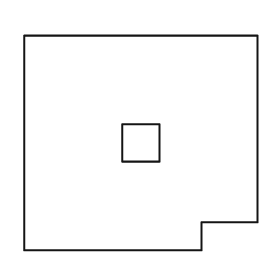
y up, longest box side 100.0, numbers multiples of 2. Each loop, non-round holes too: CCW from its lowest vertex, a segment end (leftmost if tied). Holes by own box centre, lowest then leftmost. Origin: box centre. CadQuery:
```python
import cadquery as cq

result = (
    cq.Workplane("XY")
    .moveTo(-50.0, -46.0)
    .lineTo(26.0, -46.0)
    .lineTo(26.0, -34.0)
    .lineTo(50.0, -34.0)
    .lineTo(50.0, 46.0)
    .lineTo(-50.0, 46.0)
    .close()
    .moveTo(-8.0, -8.0)
    .lineTo(8.0, -8.0)
    .lineTo(8.0, 8.0)
    .lineTo(-8.0, 8.0)
    .close()
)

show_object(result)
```